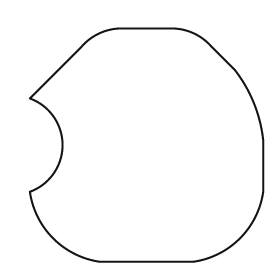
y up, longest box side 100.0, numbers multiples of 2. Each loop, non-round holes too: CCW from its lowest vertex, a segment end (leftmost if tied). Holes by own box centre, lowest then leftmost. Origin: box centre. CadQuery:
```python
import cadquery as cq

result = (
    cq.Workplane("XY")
    .moveTo(-20.0, -50.0)
    .lineTo(20.0, -50.0)
    .threePointArc((40.0, -40.0), (50.0, -20.0))
    .lineTo(50.0, 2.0)
    .threePointArc((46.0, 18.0), (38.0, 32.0))
    .lineTo(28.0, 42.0)
    .threePointArc((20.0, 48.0), (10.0, 50.0))
    .lineTo(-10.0, 50.0)
    .threePointArc((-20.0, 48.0), (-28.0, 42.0))
    .lineTo(-50.0, 20.0)
    .threePointArc((-36.0, 0.0), (-50.0, -20.0))
    .threePointArc((-40.0, -40.0), (-20.0, -50.0))
    .close()
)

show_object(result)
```